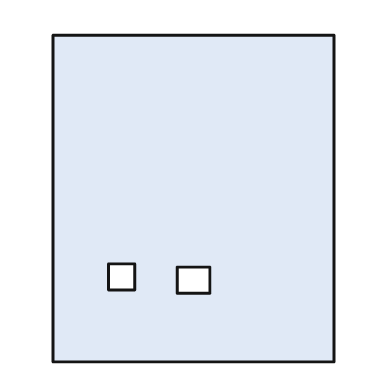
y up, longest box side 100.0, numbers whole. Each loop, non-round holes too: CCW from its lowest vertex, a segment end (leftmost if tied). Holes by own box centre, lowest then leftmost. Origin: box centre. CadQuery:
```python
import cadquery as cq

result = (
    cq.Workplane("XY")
    .moveTo(-43.0, -50.0)
    .lineTo(43.0, -50.0)
    .lineTo(43.0, 50.0)
    .lineTo(-43.0, 50.0)
    .close()
    .moveTo(-5.0, -29.0)
    .lineTo(5.0, -29.0)
    .lineTo(5.0, -21.0)
    .lineTo(-5.0, -21.0)
    .close()
    .moveTo(-26.0, -28.0)
    .lineTo(-18.0, -28.0)
    .lineTo(-18.0, -20.0)
    .lineTo(-26.0, -20.0)
    .close()
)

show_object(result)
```